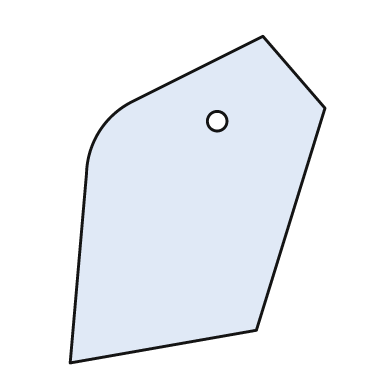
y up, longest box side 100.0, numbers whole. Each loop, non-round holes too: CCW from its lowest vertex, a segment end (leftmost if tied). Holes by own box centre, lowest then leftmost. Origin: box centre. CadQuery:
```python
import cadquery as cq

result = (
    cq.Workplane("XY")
    .moveTo(-39.0, -50.0)
    .lineTo(18.0, -40.0)
    .lineTo(39.0, 28.0)
    .lineTo(20.0, 50.0)
    .lineTo(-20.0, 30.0)
    .threePointArc((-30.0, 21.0), (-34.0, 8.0))
    .close()
    .moveTo(6.0, 24.0)
    .circle(3.0)
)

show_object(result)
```